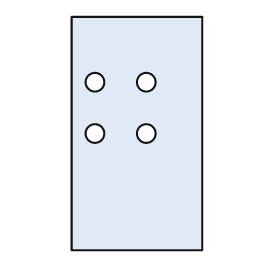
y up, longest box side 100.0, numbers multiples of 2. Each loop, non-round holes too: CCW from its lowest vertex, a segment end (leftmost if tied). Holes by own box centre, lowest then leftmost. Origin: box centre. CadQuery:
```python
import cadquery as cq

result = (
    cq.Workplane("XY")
    .moveTo(-28.0, -50.0)
    .lineTo(28.0, -50.0)
    .lineTo(28.0, 50.0)
    .lineTo(-28.0, 50.0)
    .close()
    .moveTo(-18.0, 0.0)
    .circle(4.0)
    .moveTo(4.0, 0.0)
    .circle(4.0)
    .moveTo(-18.0, 22.0)
    .circle(4.0)
    .moveTo(4.0, 22.0)
    .circle(4.0)
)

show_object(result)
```